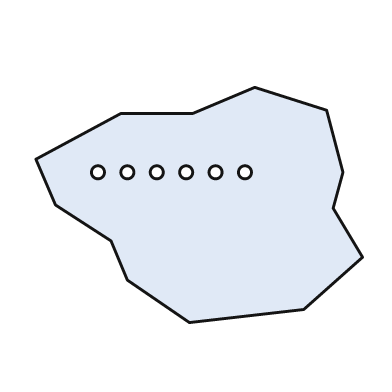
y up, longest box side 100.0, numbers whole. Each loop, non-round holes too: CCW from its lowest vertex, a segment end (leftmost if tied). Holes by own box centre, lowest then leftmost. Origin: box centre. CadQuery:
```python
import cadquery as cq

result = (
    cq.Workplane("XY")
    .moveTo(-3.0, -36.0)
    .lineTo(32.0, -32.0)
    .lineTo(50.0, -16.0)
    .lineTo(41.0, -1.0)
    .lineTo(44.0, 10.0)
    .lineTo(39.0, 29.0)
    .lineTo(17.0, 36.0)
    .lineTo(-2.0, 28.0)
    .lineTo(-24.0, 28.0)
    .lineTo(-50.0, 14.0)
    .lineTo(-44.0, 0.0)
    .lineTo(-27.0, -11.0)
    .lineTo(-22.0, -23.0)
    .close()
    .moveTo(-31.0, 10.0)
    .circle(2.0)
    .moveTo(-22.0, 10.0)
    .circle(2.0)
    .moveTo(-13.0, 10.0)
    .circle(2.0)
    .moveTo(-4.0, 10.0)
    .circle(2.0)
    .moveTo(5.0, 10.0)
    .circle(2.0)
    .moveTo(14.0, 10.0)
    .circle(2.0)
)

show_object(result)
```